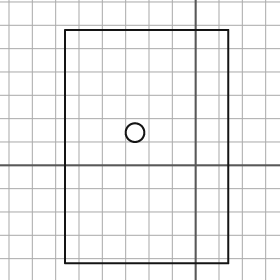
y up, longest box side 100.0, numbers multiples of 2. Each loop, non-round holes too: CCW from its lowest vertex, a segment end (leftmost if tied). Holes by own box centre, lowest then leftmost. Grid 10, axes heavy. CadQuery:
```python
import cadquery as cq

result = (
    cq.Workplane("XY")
    .moveTo(-56.0, -42.0)
    .lineTo(14.0, -42.0)
    .lineTo(14.0, 58.0)
    .lineTo(-56.0, 58.0)
    .close()
    .moveTo(-26.0, 14.0)
    .circle(4.0)
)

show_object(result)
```